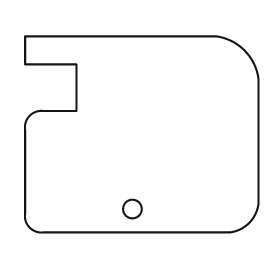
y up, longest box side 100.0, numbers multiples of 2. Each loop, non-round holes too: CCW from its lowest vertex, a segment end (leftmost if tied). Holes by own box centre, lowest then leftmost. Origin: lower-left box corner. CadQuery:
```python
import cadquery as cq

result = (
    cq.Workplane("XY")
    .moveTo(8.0, 0.0)
    .lineTo(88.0, 0.0)
    .threePointArc((96.0, 4.0), (100.0, 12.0))
    .lineTo(100.0, 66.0)
    .threePointArc((94.0, 78.0), (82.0, 84.0))
    .lineTo(0.0, 84.0)
    .lineTo(0.0, 72.0)
    .lineTo(22.0, 72.0)
    .lineTo(22.0, 52.0)
    .lineTo(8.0, 52.0)
    .threePointArc((2.0, 50.0), (0.0, 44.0))
    .lineTo(0.0, 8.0)
    .threePointArc((2.0, 2.0), (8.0, 0.0))
    .close()
    .moveTo(46.0, 10.0)
    .circle(4.0)
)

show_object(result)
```